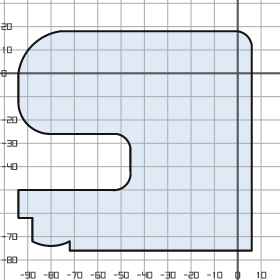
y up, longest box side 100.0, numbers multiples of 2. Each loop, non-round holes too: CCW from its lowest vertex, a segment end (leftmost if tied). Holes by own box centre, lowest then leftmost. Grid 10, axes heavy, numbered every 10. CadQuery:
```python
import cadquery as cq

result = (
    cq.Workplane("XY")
    .moveTo(-72.0, -76.0)
    .lineTo(6.0, -76.0)
    .lineTo(6.0, 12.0)
    .threePointArc((4.0, 16.0), (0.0, 18.0))
    .lineTo(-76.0, 18.0)
    .threePointArc((-88.0, 12.0), (-94.0, 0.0))
    .lineTo(-94.0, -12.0)
    .threePointArc((-90.0, -22.0), (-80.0, -26.0))
    .lineTo(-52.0, -26.0)
    .threePointArc((-48.0, -28.0), (-46.0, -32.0))
    .lineTo(-46.0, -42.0)
    .threePointArc((-48.0, -48.0), (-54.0, -50.0))
    .lineTo(-94.0, -50.0)
    .lineTo(-94.0, -62.0)
    .lineTo(-88.0, -62.0)
    .lineTo(-88.0, -72.0)
    .threePointArc((-80.0, -74.0), (-72.0, -72.0))
    .close()
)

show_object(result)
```